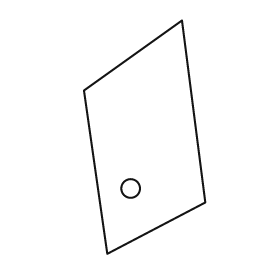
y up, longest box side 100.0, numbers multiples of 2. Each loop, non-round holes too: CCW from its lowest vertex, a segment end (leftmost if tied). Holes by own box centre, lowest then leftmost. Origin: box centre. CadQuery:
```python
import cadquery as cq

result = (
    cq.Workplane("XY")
    .moveTo(-16.0, -50.0)
    .lineTo(26.0, -28.0)
    .lineTo(16.0, 50.0)
    .lineTo(-26.0, 20.0)
    .close()
    .moveTo(-6.0, -22.0)
    .circle(4.0)
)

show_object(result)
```